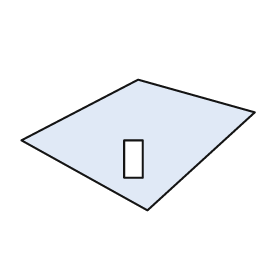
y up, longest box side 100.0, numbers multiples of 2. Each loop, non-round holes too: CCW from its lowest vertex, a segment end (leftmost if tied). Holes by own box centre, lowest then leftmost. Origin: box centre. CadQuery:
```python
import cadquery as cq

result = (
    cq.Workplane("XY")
    .moveTo(4.0, -28.0)
    .lineTo(50.0, 14.0)
    .lineTo(0.0, 28.0)
    .lineTo(-50.0, 2.0)
    .close()
    .moveTo(-6.0, -14.0)
    .lineTo(2.0, -14.0)
    .lineTo(2.0, 2.0)
    .lineTo(-6.0, 2.0)
    .close()
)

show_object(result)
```